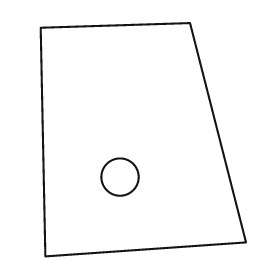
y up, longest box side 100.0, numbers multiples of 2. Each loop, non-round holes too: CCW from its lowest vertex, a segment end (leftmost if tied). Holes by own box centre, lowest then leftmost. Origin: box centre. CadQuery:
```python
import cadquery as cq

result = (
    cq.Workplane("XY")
    .moveTo(-42.0, -50.0)
    .lineTo(44.0, -44.0)
    .lineTo(20.0, 50.0)
    .lineTo(-44.0, 48.0)
    .close()
    .moveTo(-10.0, -16.0)
    .circle(8.0)
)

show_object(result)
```